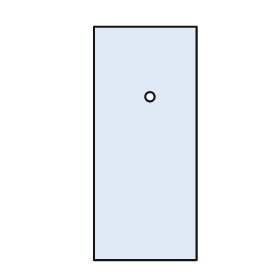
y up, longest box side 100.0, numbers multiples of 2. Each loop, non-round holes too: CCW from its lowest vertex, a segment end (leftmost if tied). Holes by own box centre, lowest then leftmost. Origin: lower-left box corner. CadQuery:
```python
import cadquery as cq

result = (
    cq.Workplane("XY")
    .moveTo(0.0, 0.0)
    .lineTo(44.0, 0.0)
    .lineTo(44.0, 100.0)
    .lineTo(0.0, 100.0)
    .close()
    .moveTo(24.0, 70.0)
    .circle(2.0)
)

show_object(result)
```